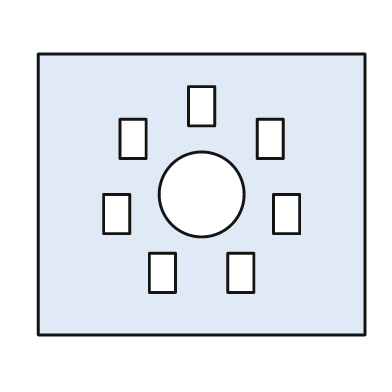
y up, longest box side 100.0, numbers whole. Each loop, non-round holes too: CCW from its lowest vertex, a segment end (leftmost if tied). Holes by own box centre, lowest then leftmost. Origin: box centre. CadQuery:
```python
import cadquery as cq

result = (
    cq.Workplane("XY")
    .moveTo(-50.0, -43.0)
    .lineTo(50.0, -43.0)
    .lineTo(50.0, 43.0)
    .lineTo(-50.0, 43.0)
    .close()
    .moveTo(-16.0, -30.0)
    .lineTo(-8.0, -30.0)
    .lineTo(-8.0, -18.0)
    .lineTo(-16.0, -18.0)
    .close()
    .moveTo(8.0, -30.0)
    .lineTo(16.0, -30.0)
    .lineTo(16.0, -18.0)
    .lineTo(8.0, -18.0)
    .close()
    .moveTo(-30.0, -12.0)
    .lineTo(-22.0, -12.0)
    .lineTo(-22.0, 0.0)
    .lineTo(-30.0, 0.0)
    .close()
    .moveTo(22.0, -12.0)
    .lineTo(30.0, -12.0)
    .lineTo(30.0, 0.0)
    .lineTo(22.0, 0.0)
    .close()
    .moveTo(0.0, 0.0)
    .circle(13.0)
    .moveTo(-25.0, 11.0)
    .lineTo(-17.0, 11.0)
    .lineTo(-17.0, 23.0)
    .lineTo(-25.0, 23.0)
    .close()
    .moveTo(17.0, 11.0)
    .lineTo(25.0, 11.0)
    .lineTo(25.0, 23.0)
    .lineTo(17.0, 23.0)
    .close()
    .moveTo(-4.0, 21.0)
    .lineTo(4.0, 21.0)
    .lineTo(4.0, 33.0)
    .lineTo(-4.0, 33.0)
    .close()
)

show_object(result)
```